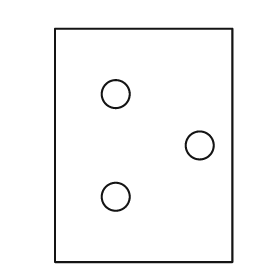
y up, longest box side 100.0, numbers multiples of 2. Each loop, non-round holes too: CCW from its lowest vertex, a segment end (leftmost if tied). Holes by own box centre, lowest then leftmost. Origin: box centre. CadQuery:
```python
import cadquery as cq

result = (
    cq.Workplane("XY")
    .moveTo(-38.0, -50.0)
    .lineTo(38.0, -50.0)
    .lineTo(38.0, 50.0)
    .lineTo(-38.0, 50.0)
    .close()
    .moveTo(-12.0, -22.0)
    .circle(6.0)
    .moveTo(24.0, 0.0)
    .circle(6.0)
    .moveTo(-12.0, 22.0)
    .circle(6.0)
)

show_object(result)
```